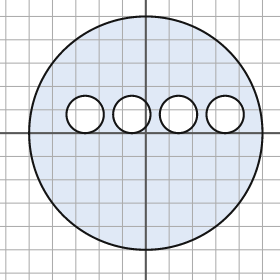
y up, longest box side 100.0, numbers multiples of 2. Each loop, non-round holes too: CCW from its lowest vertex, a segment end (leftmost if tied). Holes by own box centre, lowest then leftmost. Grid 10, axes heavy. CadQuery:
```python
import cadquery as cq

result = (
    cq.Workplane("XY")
    .moveTo(0.0, 0.0)
    .circle(50.0)
    .moveTo(-26.0, 8.0)
    .circle(8.0)
    .moveTo(-6.0, 8.0)
    .circle(8.0)
    .moveTo(14.0, 8.0)
    .circle(8.0)
    .moveTo(34.0, 8.0)
    .circle(8.0)
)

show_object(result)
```